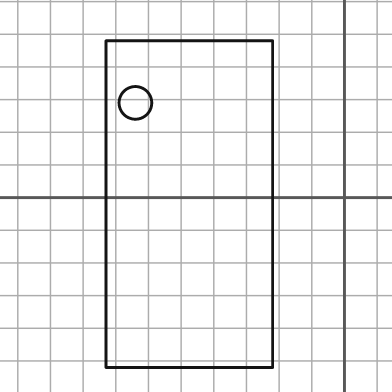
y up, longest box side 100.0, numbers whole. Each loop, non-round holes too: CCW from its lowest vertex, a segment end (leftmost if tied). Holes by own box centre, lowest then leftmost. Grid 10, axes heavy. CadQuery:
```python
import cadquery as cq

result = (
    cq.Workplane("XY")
    .moveTo(-73.0, -52.0)
    .lineTo(-22.0, -52.0)
    .lineTo(-22.0, 48.0)
    .lineTo(-73.0, 48.0)
    .close()
    .moveTo(-64.0, 29.0)
    .circle(5.0)
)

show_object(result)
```